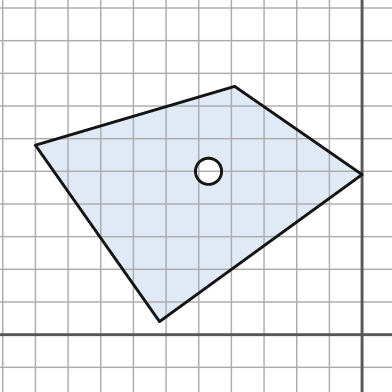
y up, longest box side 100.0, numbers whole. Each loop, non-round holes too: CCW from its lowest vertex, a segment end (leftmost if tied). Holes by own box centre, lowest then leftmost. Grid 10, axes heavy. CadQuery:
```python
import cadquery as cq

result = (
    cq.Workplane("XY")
    .moveTo(-62.0, 4.0)
    .lineTo(0.0, 49.0)
    .lineTo(-39.0, 76.0)
    .lineTo(-100.0, 58.0)
    .close()
    .moveTo(-47.0, 50.0)
    .circle(4.0)
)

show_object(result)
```